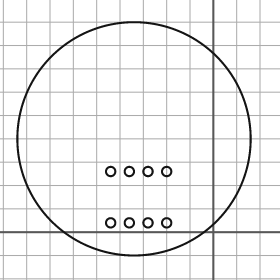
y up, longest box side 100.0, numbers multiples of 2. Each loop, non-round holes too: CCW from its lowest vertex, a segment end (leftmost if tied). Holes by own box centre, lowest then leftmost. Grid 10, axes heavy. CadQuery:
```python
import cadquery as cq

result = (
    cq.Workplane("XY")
    .moveTo(-34.0, 40.0)
    .circle(50.0)
    .moveTo(-44.0, 4.0)
    .circle(2.0)
    .moveTo(-36.0, 4.0)
    .circle(2.0)
    .moveTo(-28.0, 4.0)
    .circle(2.0)
    .moveTo(-20.0, 4.0)
    .circle(2.0)
    .moveTo(-44.0, 26.0)
    .circle(2.0)
    .moveTo(-36.0, 26.0)
    .circle(2.0)
    .moveTo(-28.0, 26.0)
    .circle(2.0)
    .moveTo(-20.0, 26.0)
    .circle(2.0)
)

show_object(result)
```